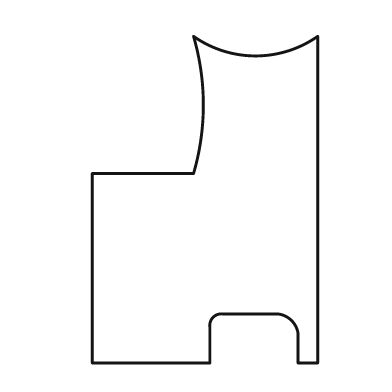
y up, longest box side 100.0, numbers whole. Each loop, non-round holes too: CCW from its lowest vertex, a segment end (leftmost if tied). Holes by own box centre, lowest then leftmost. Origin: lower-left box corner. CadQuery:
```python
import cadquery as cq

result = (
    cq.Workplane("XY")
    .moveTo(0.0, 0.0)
    .lineTo(36.0, 0.0)
    .lineTo(36.0, 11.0)
    .threePointArc((37.0, 14.0), (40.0, 15.0))
    .lineTo(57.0, 15.0)
    .threePointArc((61.0, 13.0), (63.0, 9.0))
    .lineTo(63.0, 0.0)
    .lineTo(69.0, 0.0)
    .lineTo(69.0, 100.0)
    .threePointArc((50.0, 94.0), (31.0, 100.0))
    .threePointArc((34.0, 79.0), (31.0, 58.0))
    .lineTo(0.0, 58.0)
    .close()
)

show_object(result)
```